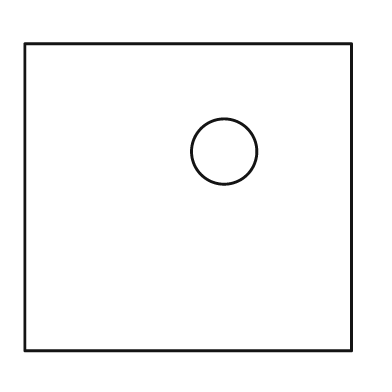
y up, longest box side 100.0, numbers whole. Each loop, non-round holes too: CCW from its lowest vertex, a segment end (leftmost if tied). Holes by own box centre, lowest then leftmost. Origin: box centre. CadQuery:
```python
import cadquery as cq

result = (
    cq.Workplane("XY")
    .moveTo(-50.0, -47.0)
    .lineTo(50.0, -47.0)
    .lineTo(50.0, 47.0)
    .lineTo(-50.0, 47.0)
    .close()
    .moveTo(11.0, 14.0)
    .circle(10.0)
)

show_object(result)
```